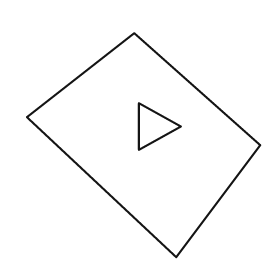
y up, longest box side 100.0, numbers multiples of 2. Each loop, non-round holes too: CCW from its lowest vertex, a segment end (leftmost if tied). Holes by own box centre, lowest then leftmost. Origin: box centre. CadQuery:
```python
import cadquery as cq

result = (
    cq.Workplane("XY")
    .moveTo(14.0, -48.0)
    .lineTo(50.0, 0.0)
    .lineTo(-4.0, 48.0)
    .lineTo(-50.0, 12.0)
    .close()
    .moveTo(-2.0, -2.0)
    .lineTo(16.0, 8.0)
    .lineTo(-2.0, 18.0)
    .close()
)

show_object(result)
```